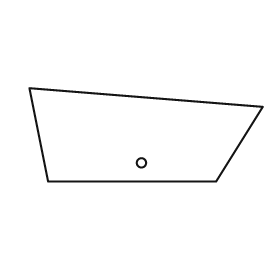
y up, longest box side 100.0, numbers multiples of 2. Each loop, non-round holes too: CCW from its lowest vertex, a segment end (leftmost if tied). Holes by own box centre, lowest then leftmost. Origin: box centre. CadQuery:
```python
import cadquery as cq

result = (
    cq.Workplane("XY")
    .moveTo(-42.0, -20.0)
    .lineTo(30.0, -20.0)
    .lineTo(50.0, 12.0)
    .lineTo(-50.0, 20.0)
    .close()
    .moveTo(-2.0, -12.0)
    .circle(2.0)
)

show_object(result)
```